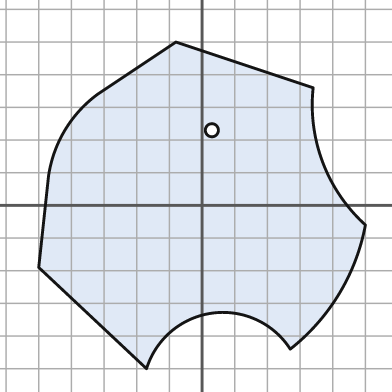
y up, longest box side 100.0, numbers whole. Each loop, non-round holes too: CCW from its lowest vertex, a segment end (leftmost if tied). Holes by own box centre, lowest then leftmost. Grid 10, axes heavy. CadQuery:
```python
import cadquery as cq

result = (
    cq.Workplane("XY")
    .moveTo(-17.0, -50.0)
    .threePointArc((3.0, -33.0), (27.0, -44.0))
    .threePointArc((42.0, -27.0), (50.0, -6.0))
    .threePointArc((37.0, 13.0), (34.0, 36.0))
    .lineTo(-8.0, 50.0)
    .lineTo(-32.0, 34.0)
    .threePointArc((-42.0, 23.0), (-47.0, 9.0))
    .lineTo(-50.0, -19.0)
    .close()
    .moveTo(3.0, 23.0)
    .circle(2.0)
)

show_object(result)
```